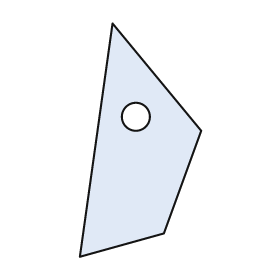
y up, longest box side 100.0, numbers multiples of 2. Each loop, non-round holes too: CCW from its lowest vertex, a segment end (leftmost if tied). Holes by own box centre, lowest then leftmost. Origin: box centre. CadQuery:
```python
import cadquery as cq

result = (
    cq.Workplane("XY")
    .moveTo(-26.0, -50.0)
    .lineTo(10.0, -40.0)
    .lineTo(26.0, 4.0)
    .lineTo(-12.0, 50.0)
    .close()
    .moveTo(-2.0, 10.0)
    .circle(6.0)
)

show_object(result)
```